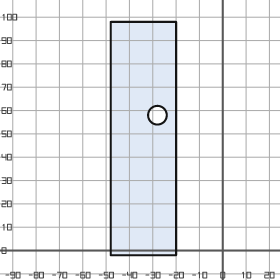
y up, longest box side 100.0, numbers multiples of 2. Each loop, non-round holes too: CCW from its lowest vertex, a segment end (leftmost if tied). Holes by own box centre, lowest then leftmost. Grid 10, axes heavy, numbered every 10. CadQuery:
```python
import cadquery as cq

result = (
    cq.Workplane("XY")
    .moveTo(-48.0, -2.0)
    .lineTo(-20.0, -2.0)
    .lineTo(-20.0, 98.0)
    .lineTo(-48.0, 98.0)
    .close()
    .moveTo(-28.0, 58.0)
    .circle(4.0)
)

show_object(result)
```